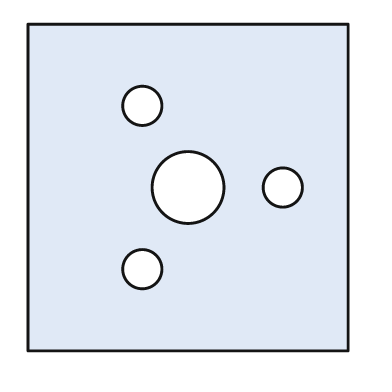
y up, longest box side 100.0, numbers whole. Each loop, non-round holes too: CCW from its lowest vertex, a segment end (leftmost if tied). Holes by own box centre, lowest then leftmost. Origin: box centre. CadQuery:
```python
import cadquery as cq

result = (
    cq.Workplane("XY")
    .moveTo(-49.0, -50.0)
    .lineTo(49.0, -50.0)
    .lineTo(49.0, 50.0)
    .lineTo(-49.0, 50.0)
    .close()
    .moveTo(-14.0, -25.0)
    .circle(6.0)
    .moveTo(0.0, 0.0)
    .circle(11.0)
    .moveTo(29.0, 0.0)
    .circle(6.0)
    .moveTo(-14.0, 25.0)
    .circle(6.0)
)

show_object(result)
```